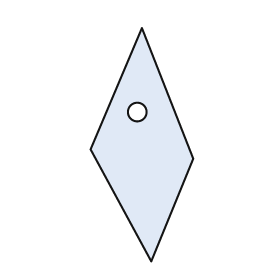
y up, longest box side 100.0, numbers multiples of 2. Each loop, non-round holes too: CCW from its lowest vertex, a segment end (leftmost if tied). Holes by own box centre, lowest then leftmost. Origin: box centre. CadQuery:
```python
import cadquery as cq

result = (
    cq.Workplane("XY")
    .moveTo(4.0, -50.0)
    .lineTo(22.0, -6.0)
    .lineTo(0.0, 50.0)
    .lineTo(-22.0, -2.0)
    .close()
    .moveTo(-2.0, 14.0)
    .circle(4.0)
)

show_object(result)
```